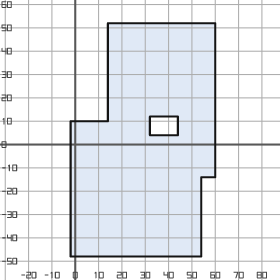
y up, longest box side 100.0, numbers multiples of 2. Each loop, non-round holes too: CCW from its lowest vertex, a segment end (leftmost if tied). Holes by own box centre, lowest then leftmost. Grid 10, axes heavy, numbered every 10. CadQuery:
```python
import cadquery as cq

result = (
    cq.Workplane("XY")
    .moveTo(-2.0, -48.0)
    .lineTo(54.0, -48.0)
    .lineTo(54.0, -14.0)
    .lineTo(60.0, -14.0)
    .lineTo(60.0, 52.0)
    .lineTo(14.0, 52.0)
    .lineTo(14.0, 10.0)
    .lineTo(-2.0, 10.0)
    .close()
    .moveTo(32.0, 4.0)
    .lineTo(44.0, 4.0)
    .lineTo(44.0, 12.0)
    .lineTo(32.0, 12.0)
    .close()
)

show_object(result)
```